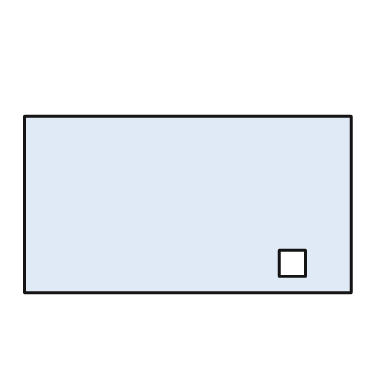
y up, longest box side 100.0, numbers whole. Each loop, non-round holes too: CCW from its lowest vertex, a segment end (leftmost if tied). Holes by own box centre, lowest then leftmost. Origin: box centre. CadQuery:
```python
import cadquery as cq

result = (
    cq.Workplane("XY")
    .moveTo(-50.0, -27.0)
    .lineTo(50.0, -27.0)
    .lineTo(50.0, 27.0)
    .lineTo(-50.0, 27.0)
    .close()
    .moveTo(28.0, -22.0)
    .lineTo(36.0, -22.0)
    .lineTo(36.0, -14.0)
    .lineTo(28.0, -14.0)
    .close()
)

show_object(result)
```